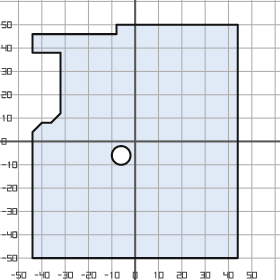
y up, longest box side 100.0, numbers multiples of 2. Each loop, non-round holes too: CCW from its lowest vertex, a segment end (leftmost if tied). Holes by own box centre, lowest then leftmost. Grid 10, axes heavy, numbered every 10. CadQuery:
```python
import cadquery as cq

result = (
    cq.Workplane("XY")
    .moveTo(-44.0, -50.0)
    .lineTo(44.0, -50.0)
    .lineTo(44.0, 50.0)
    .lineTo(-8.0, 50.0)
    .lineTo(-8.0, 46.0)
    .lineTo(-44.0, 46.0)
    .lineTo(-44.0, 38.0)
    .lineTo(-32.0, 38.0)
    .lineTo(-32.0, 12.0)
    .lineTo(-36.0, 8.0)
    .lineTo(-40.0, 8.0)
    .lineTo(-44.0, 4.0)
    .close()
    .moveTo(-6.0, -6.0)
    .circle(4.0)
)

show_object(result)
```